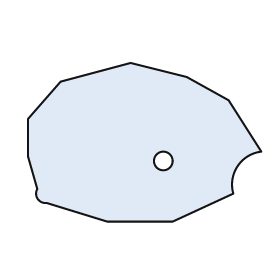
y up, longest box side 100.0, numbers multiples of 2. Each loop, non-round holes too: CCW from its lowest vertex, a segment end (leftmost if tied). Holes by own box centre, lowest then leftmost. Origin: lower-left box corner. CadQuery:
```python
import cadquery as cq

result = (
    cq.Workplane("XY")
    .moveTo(34.0, 0.0)
    .lineTo(62.0, 0.0)
    .lineTo(88.0, 12.0)
    .threePointArc((90.0, 24.0), (100.0, 30.0))
    .lineTo(86.0, 52.0)
    .lineTo(68.0, 62.0)
    .lineTo(44.0, 68.0)
    .lineTo(14.0, 60.0)
    .lineTo(0.0, 44.0)
    .lineTo(0.0, 28.0)
    .lineTo(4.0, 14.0)
    .threePointArc((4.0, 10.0), (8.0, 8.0))
    .close()
    .moveTo(58.0, 26.0)
    .circle(4.0)
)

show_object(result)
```